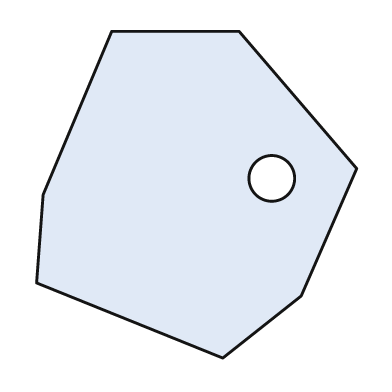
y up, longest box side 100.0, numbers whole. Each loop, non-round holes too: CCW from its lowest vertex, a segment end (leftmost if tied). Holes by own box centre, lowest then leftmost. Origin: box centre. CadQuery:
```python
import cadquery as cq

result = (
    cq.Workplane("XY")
    .moveTo(8.0, -50.0)
    .lineTo(32.0, -31.0)
    .lineTo(49.0, 8.0)
    .lineTo(13.0, 50.0)
    .lineTo(-26.0, 50.0)
    .lineTo(-47.0, 0.0)
    .lineTo(-49.0, -27.0)
    .close()
    .moveTo(23.0, 5.0)
    .circle(7.0)
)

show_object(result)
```